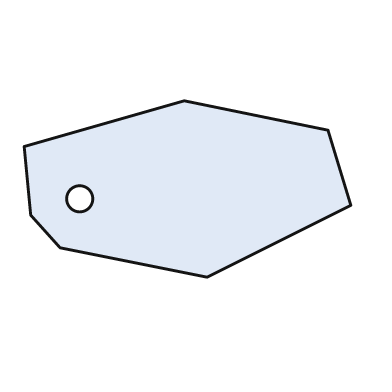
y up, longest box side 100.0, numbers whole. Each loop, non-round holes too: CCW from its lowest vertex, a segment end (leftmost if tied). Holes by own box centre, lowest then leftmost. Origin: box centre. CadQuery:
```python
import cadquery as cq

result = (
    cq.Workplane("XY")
    .moveTo(6.0, -27.0)
    .lineTo(50.0, -5.0)
    .lineTo(43.0, 18.0)
    .lineTo(-1.0, 27.0)
    .lineTo(-50.0, 13.0)
    .lineTo(-48.0, -8.0)
    .lineTo(-39.0, -18.0)
    .close()
    .moveTo(-33.0, -3.0)
    .circle(4.0)
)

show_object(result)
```